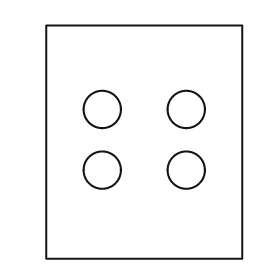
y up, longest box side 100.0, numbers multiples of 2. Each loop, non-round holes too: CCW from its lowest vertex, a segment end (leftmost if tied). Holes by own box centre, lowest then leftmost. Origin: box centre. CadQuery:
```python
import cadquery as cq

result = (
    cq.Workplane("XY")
    .moveTo(-42.0, -50.0)
    .lineTo(42.0, -50.0)
    .lineTo(42.0, 50.0)
    .lineTo(-42.0, 50.0)
    .close()
    .moveTo(-18.0, -12.0)
    .circle(8.0)
    .moveTo(18.0, -12.0)
    .circle(8.0)
    .moveTo(-18.0, 14.0)
    .circle(8.0)
    .moveTo(18.0, 14.0)
    .circle(8.0)
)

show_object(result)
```